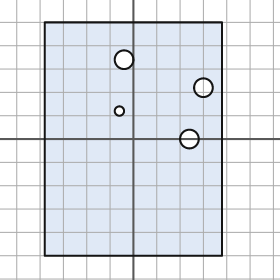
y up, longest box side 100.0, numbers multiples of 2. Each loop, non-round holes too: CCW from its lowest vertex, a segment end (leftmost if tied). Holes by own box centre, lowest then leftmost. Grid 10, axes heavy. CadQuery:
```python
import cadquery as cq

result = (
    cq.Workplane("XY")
    .moveTo(-38.0, -50.0)
    .lineTo(38.0, -50.0)
    .lineTo(38.0, 50.0)
    .lineTo(-38.0, 50.0)
    .close()
    .moveTo(24.0, 0.0)
    .circle(4.0)
    .moveTo(-6.0, 12.0)
    .circle(2.0)
    .moveTo(30.0, 22.0)
    .circle(4.0)
    .moveTo(-4.0, 34.0)
    .circle(4.0)
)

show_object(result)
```